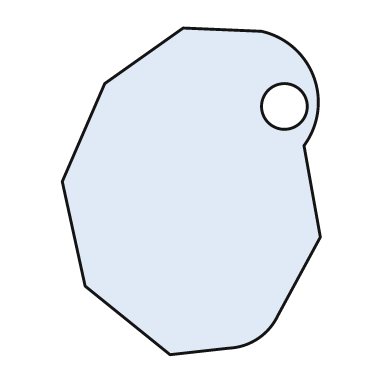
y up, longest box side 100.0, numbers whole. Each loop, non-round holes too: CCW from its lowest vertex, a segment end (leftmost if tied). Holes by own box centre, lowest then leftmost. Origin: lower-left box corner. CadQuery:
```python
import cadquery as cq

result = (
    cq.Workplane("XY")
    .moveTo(33.0, 0.0)
    .lineTo(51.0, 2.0)
    .threePointArc((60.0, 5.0), (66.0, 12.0))
    .lineTo(79.0, 36.0)
    .lineTo(74.0, 64.0)
    .threePointArc((77.0, 85.0), (61.0, 99.0))
    .lineTo(37.0, 100.0)
    .lineTo(13.0, 83.0)
    .lineTo(0.0, 53.0)
    .lineTo(7.0, 21.0)
    .close()
    .moveTo(68.0, 76.0)
    .circle(7.0)
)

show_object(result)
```